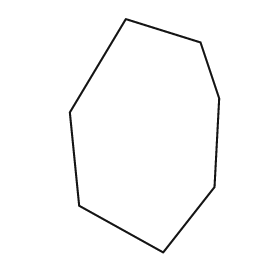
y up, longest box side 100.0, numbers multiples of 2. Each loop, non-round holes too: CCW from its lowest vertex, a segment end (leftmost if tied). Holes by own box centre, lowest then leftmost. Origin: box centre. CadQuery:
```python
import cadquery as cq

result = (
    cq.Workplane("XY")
    .moveTo(8.0, -50.0)
    .lineTo(30.0, -22.0)
    .lineTo(32.0, 16.0)
    .lineTo(24.0, 40.0)
    .lineTo(-8.0, 50.0)
    .lineTo(-32.0, 10.0)
    .lineTo(-28.0, -30.0)
    .close()
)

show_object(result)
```